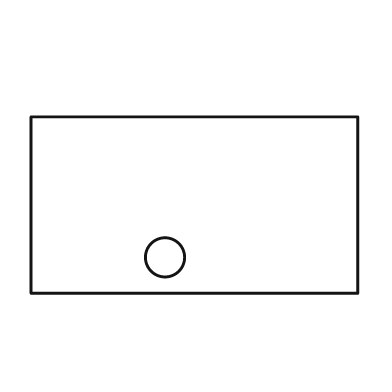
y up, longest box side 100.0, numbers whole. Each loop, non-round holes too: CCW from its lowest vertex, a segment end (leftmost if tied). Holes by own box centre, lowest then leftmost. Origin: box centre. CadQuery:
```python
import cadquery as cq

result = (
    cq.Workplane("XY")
    .moveTo(-50.0, -27.0)
    .lineTo(50.0, -27.0)
    .lineTo(50.0, 27.0)
    .lineTo(-50.0, 27.0)
    .close()
    .moveTo(-9.0, -16.0)
    .circle(6.0)
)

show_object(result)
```